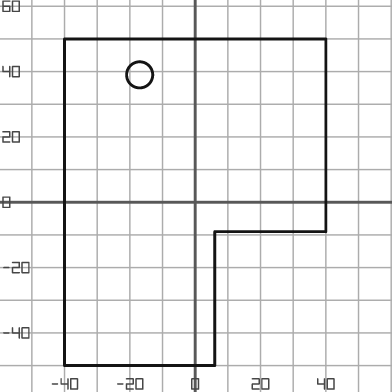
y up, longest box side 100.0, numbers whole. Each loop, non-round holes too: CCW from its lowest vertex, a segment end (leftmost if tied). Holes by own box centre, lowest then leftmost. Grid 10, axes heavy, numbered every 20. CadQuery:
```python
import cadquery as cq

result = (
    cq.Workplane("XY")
    .moveTo(-40.0, -50.0)
    .lineTo(6.0, -50.0)
    .lineTo(6.0, -9.0)
    .lineTo(40.0, -9.0)
    .lineTo(40.0, 50.0)
    .lineTo(-40.0, 50.0)
    .close()
    .moveTo(-17.0, 39.0)
    .circle(4.0)
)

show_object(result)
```